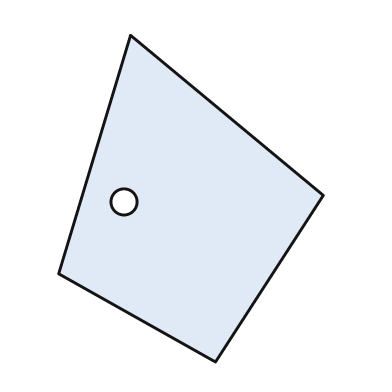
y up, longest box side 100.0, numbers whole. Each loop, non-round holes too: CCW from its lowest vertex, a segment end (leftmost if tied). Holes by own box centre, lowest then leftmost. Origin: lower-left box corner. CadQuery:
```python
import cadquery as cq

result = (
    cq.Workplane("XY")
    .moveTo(48.0, 0.0)
    .lineTo(81.0, 51.0)
    .lineTo(22.0, 100.0)
    .lineTo(0.0, 27.0)
    .close()
    .moveTo(20.0, 49.0)
    .circle(4.0)
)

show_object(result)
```